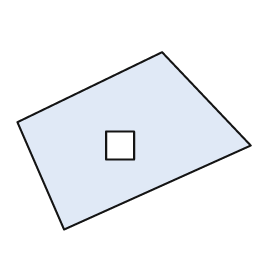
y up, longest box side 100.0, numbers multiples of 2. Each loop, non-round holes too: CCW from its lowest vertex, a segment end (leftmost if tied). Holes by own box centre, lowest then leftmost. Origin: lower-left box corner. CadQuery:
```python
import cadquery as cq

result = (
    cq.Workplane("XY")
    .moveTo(20.0, 0.0)
    .lineTo(100.0, 36.0)
    .lineTo(62.0, 76.0)
    .lineTo(0.0, 46.0)
    .close()
    .moveTo(38.0, 30.0)
    .lineTo(50.0, 30.0)
    .lineTo(50.0, 42.0)
    .lineTo(38.0, 42.0)
    .close()
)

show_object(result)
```